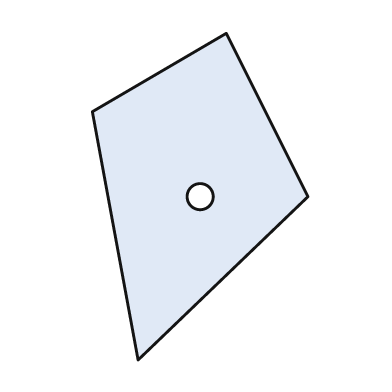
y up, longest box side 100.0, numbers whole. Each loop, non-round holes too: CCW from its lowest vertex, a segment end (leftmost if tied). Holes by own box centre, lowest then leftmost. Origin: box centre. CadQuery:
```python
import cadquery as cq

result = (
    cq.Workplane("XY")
    .moveTo(-19.0, -50.0)
    .lineTo(33.0, 0.0)
    .lineTo(8.0, 50.0)
    .lineTo(-33.0, 26.0)
    .close()
    .moveTo(0.0, 0.0)
    .circle(4.0)
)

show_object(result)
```